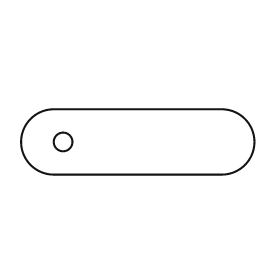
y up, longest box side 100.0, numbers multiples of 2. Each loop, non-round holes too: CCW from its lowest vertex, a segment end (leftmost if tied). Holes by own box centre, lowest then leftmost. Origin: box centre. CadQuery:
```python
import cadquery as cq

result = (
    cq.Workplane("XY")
    .moveTo(-36.0, -14.0)
    .lineTo(36.0, -14.0)
    .threePointArc((50.0, 0.0), (36.0, 14.0))
    .lineTo(-36.0, 14.0)
    .threePointArc((-50.0, 0.0), (-36.0, -14.0))
    .close()
    .moveTo(-32.0, 0.0)
    .circle(4.0)
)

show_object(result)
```